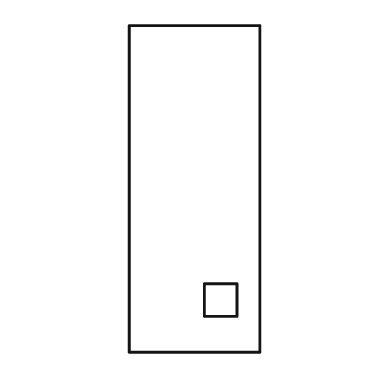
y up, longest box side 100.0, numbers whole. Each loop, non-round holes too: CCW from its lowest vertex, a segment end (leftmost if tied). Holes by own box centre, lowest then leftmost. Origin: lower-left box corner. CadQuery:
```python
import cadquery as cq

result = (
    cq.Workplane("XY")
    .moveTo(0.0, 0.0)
    .lineTo(40.0, 0.0)
    .lineTo(40.0, 100.0)
    .lineTo(0.0, 100.0)
    .close()
    .moveTo(23.0, 11.0)
    .lineTo(33.0, 11.0)
    .lineTo(33.0, 21.0)
    .lineTo(23.0, 21.0)
    .close()
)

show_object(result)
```